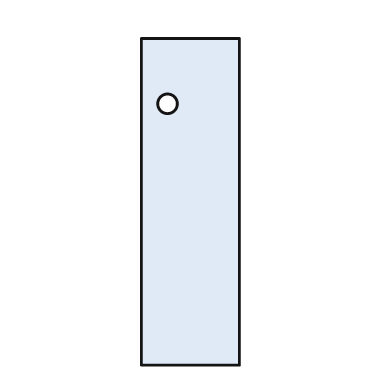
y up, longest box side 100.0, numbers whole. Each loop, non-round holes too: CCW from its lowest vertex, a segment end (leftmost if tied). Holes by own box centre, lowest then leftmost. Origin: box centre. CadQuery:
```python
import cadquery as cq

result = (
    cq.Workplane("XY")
    .moveTo(-15.0, -50.0)
    .lineTo(15.0, -50.0)
    .lineTo(15.0, 50.0)
    .lineTo(-15.0, 50.0)
    .close()
    .moveTo(-7.0, 30.0)
    .circle(3.0)
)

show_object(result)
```